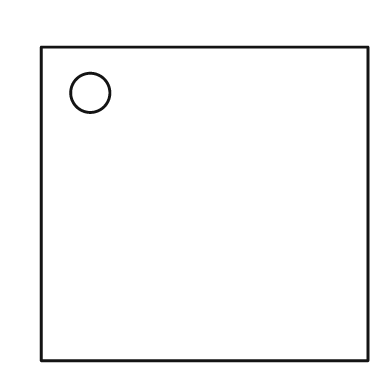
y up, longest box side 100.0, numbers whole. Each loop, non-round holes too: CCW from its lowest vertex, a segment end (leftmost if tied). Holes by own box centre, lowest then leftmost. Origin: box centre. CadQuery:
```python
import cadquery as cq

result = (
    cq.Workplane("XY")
    .moveTo(-50.0, -48.0)
    .lineTo(50.0, -48.0)
    .lineTo(50.0, 48.0)
    .lineTo(-50.0, 48.0)
    .close()
    .moveTo(-35.0, 34.0)
    .circle(6.0)
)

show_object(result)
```